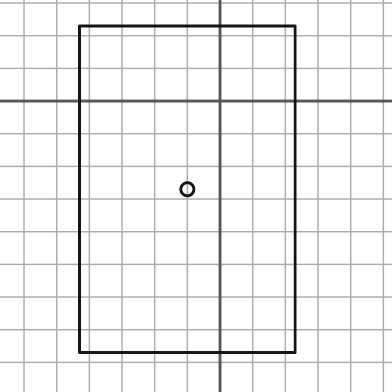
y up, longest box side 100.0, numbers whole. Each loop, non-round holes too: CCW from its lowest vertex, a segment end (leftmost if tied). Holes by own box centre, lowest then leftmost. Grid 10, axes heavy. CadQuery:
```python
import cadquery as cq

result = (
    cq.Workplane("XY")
    .moveTo(-43.0, -77.0)
    .lineTo(23.0, -77.0)
    .lineTo(23.0, 23.0)
    .lineTo(-43.0, 23.0)
    .close()
    .moveTo(-10.0, -27.0)
    .circle(2.0)
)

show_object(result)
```